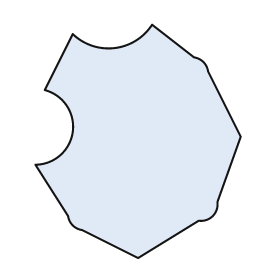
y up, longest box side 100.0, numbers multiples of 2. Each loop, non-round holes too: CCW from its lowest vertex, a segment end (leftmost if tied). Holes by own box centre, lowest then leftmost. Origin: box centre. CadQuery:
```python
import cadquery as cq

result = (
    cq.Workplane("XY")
    .moveTo(0.0, -50.0)
    .lineTo(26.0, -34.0)
    .threePointArc((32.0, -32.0), (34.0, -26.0))
    .lineTo(44.0, 2.0)
    .lineTo(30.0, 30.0)
    .threePointArc((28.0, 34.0), (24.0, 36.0))
    .lineTo(6.0, 50.0)
    .threePointArc((-10.0, 40.0), (-28.0, 46.0))
    .lineTo(-40.0, 22.0)
    .threePointArc((-28.0, 4.0), (-44.0, -10.0))
    .lineTo(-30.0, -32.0)
    .threePointArc((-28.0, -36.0), (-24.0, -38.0))
    .close()
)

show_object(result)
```